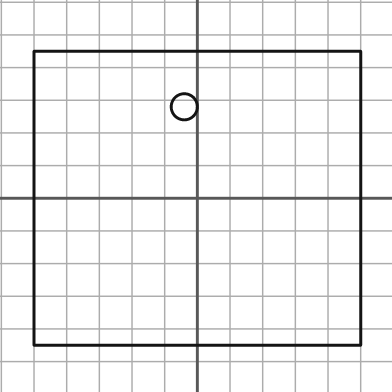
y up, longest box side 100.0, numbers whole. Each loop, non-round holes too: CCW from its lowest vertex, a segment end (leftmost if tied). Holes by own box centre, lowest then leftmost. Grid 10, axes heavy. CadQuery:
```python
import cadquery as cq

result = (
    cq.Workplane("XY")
    .moveTo(-50.0, -45.0)
    .lineTo(50.0, -45.0)
    .lineTo(50.0, 45.0)
    .lineTo(-50.0, 45.0)
    .close()
    .moveTo(-4.0, 28.0)
    .circle(4.0)
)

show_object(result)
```